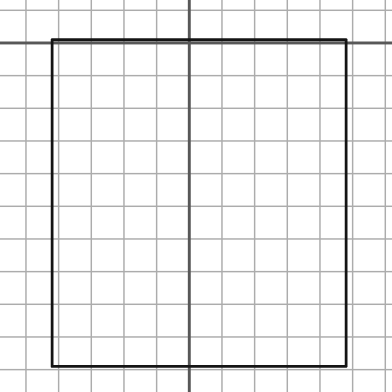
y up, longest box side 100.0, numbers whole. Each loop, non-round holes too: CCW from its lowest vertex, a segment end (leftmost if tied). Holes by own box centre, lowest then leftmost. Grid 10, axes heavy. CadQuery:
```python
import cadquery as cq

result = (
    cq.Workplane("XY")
    .moveTo(-42.0, -99.0)
    .lineTo(48.0, -99.0)
    .lineTo(48.0, 1.0)
    .lineTo(-42.0, 1.0)
    .close()
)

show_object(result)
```